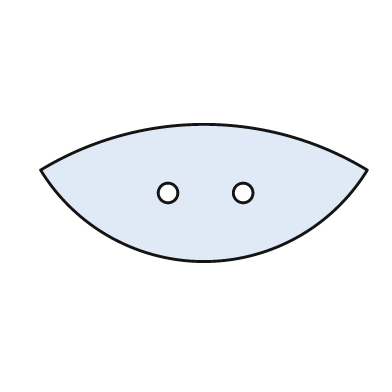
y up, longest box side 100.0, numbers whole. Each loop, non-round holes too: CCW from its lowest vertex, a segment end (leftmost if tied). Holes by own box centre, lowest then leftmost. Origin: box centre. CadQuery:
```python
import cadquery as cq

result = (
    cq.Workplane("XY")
    .moveTo(-50.0, 7.0)
    .threePointArc((0.0, -21.0), (50.0, 7.0))
    .threePointArc((0.0, 21.0), (-50.0, 7.0))
    .close()
    .moveTo(-11.0, 0.0)
    .circle(3.0)
    .moveTo(12.0, 0.0)
    .circle(3.0)
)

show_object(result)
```